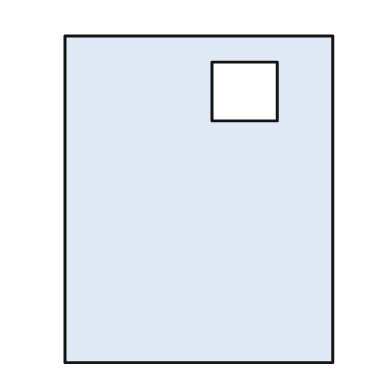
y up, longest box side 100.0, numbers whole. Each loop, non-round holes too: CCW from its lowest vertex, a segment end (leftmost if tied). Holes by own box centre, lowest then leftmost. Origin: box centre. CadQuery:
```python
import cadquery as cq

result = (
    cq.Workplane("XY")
    .moveTo(-41.0, -50.0)
    .lineTo(41.0, -50.0)
    .lineTo(41.0, 50.0)
    .lineTo(-41.0, 50.0)
    .close()
    .moveTo(4.0, 24.0)
    .lineTo(24.0, 24.0)
    .lineTo(24.0, 42.0)
    .lineTo(4.0, 42.0)
    .close()
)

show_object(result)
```